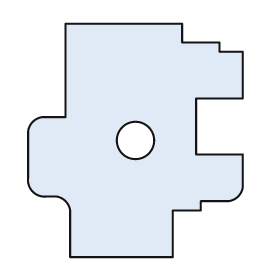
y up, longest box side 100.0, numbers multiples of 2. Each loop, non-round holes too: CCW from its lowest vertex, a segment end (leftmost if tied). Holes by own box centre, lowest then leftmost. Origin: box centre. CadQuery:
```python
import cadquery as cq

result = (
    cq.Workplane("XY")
    .moveTo(-28.0, -50.0)
    .lineTo(16.0, -50.0)
    .lineTo(16.0, -30.0)
    .lineTo(28.0, -30.0)
    .lineTo(28.0, -26.0)
    .lineTo(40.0, -26.0)
    .threePointArc((44.0, -24.0), (46.0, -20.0))
    .lineTo(46.0, -6.0)
    .lineTo(26.0, -6.0)
    .lineTo(26.0, 18.0)
    .lineTo(46.0, 18.0)
    .lineTo(46.0, 38.0)
    .lineTo(36.0, 38.0)
    .lineTo(36.0, 42.0)
    .lineTo(20.0, 42.0)
    .lineTo(20.0, 50.0)
    .lineTo(-30.0, 50.0)
    .lineTo(-30.0, 10.0)
    .lineTo(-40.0, 10.0)
    .threePointArc((-44.0, 8.0), (-46.0, 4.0))
    .lineTo(-46.0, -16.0)
    .threePointArc((-44.0, -22.0), (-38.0, -24.0))
    .lineTo(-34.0, -24.0)
    .threePointArc((-30.0, -26.0), (-28.0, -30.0))
    .close()
    .moveTo(0.0, 0.0)
    .circle(8.0)
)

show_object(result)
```